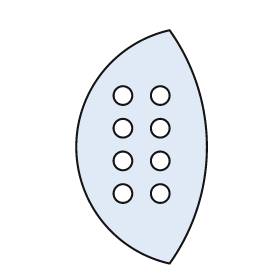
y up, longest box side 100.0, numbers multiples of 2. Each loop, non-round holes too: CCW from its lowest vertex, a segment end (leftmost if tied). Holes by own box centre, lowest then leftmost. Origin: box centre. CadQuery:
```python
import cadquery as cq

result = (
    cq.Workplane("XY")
    .moveTo(12.0, -50.0)
    .threePointArc((28.0, 0.0), (12.0, 50.0))
    .threePointArc((-28.0, 0.0), (12.0, -50.0))
    .close()
    .moveTo(-8.0, -20.0)
    .circle(4.0)
    .moveTo(8.0, -20.0)
    .circle(4.0)
    .moveTo(-8.0, -6.0)
    .circle(4.0)
    .moveTo(8.0, -6.0)
    .circle(4.0)
    .moveTo(-8.0, 8.0)
    .circle(4.0)
    .moveTo(8.0, 8.0)
    .circle(4.0)
    .moveTo(-8.0, 22.0)
    .circle(4.0)
    .moveTo(8.0, 22.0)
    .circle(4.0)
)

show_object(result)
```